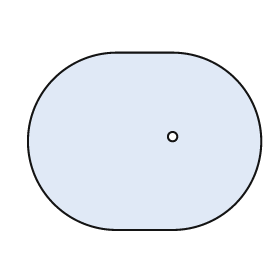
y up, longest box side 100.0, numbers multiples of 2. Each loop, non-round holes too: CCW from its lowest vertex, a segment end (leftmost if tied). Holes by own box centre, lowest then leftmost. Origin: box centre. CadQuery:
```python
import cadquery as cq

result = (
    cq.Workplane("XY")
    .moveTo(-12.0, -38.0)
    .lineTo(12.0, -38.0)
    .threePointArc((50.0, 0.0), (12.0, 38.0))
    .lineTo(-12.0, 38.0)
    .threePointArc((-50.0, 0.0), (-12.0, -38.0))
    .close()
    .moveTo(12.0, 2.0)
    .circle(2.0)
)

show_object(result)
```